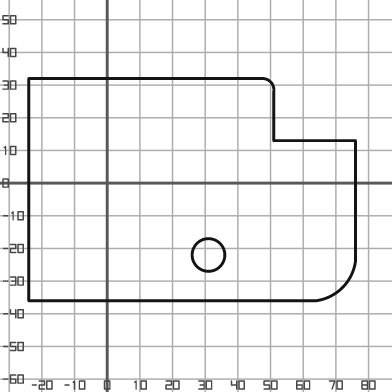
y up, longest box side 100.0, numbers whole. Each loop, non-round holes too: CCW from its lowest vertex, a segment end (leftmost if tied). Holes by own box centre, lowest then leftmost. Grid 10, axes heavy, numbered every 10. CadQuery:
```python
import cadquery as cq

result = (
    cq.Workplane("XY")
    .moveTo(-24.0, -36.0)
    .lineTo(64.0, -36.0)
    .threePointArc((72.0, -32.0), (76.0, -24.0))
    .lineTo(76.0, 13.0)
    .lineTo(51.0, 13.0)
    .lineTo(51.0, 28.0)
    .threePointArc((50.0, 31.0), (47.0, 32.0))
    .lineTo(-24.0, 32.0)
    .close()
    .moveTo(31.0, -22.0)
    .circle(5.0)
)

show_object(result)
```